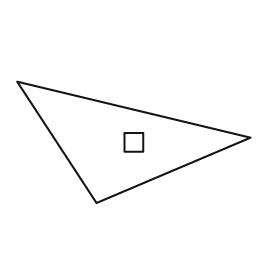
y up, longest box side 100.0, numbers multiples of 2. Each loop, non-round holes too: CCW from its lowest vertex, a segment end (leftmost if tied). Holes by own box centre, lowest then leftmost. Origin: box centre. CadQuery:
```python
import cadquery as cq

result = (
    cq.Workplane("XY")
    .moveTo(-16.0, -26.0)
    .lineTo(50.0, 2.0)
    .lineTo(-50.0, 26.0)
    .close()
    .moveTo(-4.0, -4.0)
    .lineTo(4.0, -4.0)
    .lineTo(4.0, 4.0)
    .lineTo(-4.0, 4.0)
    .close()
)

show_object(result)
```